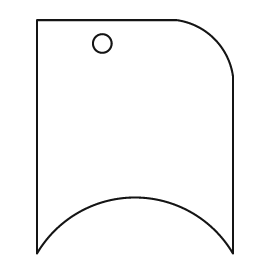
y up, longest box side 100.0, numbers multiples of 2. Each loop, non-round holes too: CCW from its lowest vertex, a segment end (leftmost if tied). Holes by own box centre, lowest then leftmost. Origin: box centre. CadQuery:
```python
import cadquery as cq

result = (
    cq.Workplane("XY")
    .moveTo(-42.0, -50.0)
    .threePointArc((0.0, -26.0), (42.0, -50.0))
    .lineTo(42.0, 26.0)
    .threePointArc((34.0, 42.0), (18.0, 50.0))
    .lineTo(-42.0, 50.0)
    .close()
    .moveTo(-14.0, 40.0)
    .circle(4.0)
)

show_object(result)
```